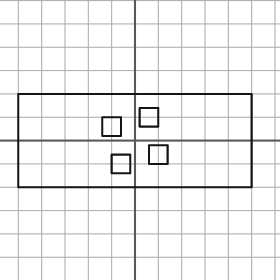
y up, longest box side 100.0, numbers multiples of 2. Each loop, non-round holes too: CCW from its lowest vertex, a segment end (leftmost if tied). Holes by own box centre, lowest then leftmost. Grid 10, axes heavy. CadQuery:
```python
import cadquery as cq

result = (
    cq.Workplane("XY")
    .moveTo(-50.0, -20.0)
    .lineTo(50.0, -20.0)
    .lineTo(50.0, 20.0)
    .lineTo(-50.0, 20.0)
    .close()
    .moveTo(-10.0, -14.0)
    .lineTo(-2.0, -14.0)
    .lineTo(-2.0, -6.0)
    .lineTo(-10.0, -6.0)
    .close()
    .moveTo(6.0, -10.0)
    .lineTo(14.0, -10.0)
    .lineTo(14.0, -2.0)
    .lineTo(6.0, -2.0)
    .close()
    .moveTo(-14.0, 2.0)
    .lineTo(-6.0, 2.0)
    .lineTo(-6.0, 10.0)
    .lineTo(-14.0, 10.0)
    .close()
    .moveTo(2.0, 6.0)
    .lineTo(10.0, 6.0)
    .lineTo(10.0, 14.0)
    .lineTo(2.0, 14.0)
    .close()
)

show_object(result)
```